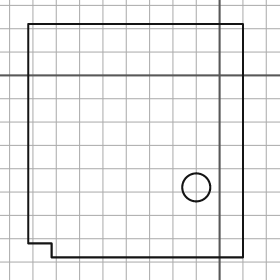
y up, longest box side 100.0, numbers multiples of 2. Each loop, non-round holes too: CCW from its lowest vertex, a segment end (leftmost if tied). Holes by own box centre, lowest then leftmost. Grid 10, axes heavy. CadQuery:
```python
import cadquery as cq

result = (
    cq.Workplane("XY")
    .moveTo(-72.0, -78.0)
    .lineTo(10.0, -78.0)
    .lineTo(10.0, 22.0)
    .lineTo(-82.0, 22.0)
    .lineTo(-82.0, -72.0)
    .lineTo(-72.0, -72.0)
    .close()
    .moveTo(-10.0, -48.0)
    .circle(6.0)
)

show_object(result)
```